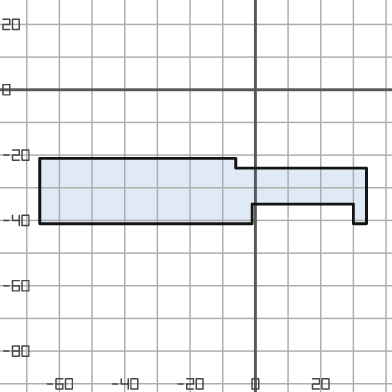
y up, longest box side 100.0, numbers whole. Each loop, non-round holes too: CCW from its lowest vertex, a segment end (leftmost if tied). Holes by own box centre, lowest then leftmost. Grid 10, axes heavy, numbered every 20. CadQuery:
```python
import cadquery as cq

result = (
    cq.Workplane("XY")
    .moveTo(-66.0, -41.0)
    .lineTo(-1.0, -41.0)
    .lineTo(-1.0, -35.0)
    .lineTo(30.0, -35.0)
    .lineTo(30.0, -41.0)
    .lineTo(34.0, -41.0)
    .lineTo(34.0, -24.0)
    .lineTo(-6.0, -24.0)
    .lineTo(-6.0, -21.0)
    .lineTo(-66.0, -21.0)
    .close()
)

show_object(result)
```